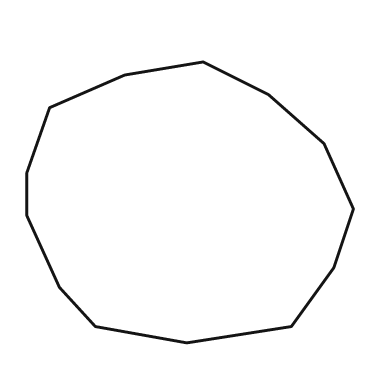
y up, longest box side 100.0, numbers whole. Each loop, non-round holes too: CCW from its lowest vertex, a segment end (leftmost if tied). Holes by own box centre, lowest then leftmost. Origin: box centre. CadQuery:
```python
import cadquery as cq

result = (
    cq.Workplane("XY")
    .moveTo(-1.0, -43.0)
    .lineTo(31.0, -38.0)
    .lineTo(44.0, -20.0)
    .lineTo(50.0, -2.0)
    .lineTo(41.0, 18.0)
    .lineTo(24.0, 33.0)
    .lineTo(4.0, 43.0)
    .lineTo(-20.0, 39.0)
    .lineTo(-43.0, 29.0)
    .lineTo(-50.0, 9.0)
    .lineTo(-50.0, -4.0)
    .lineTo(-40.0, -26.0)
    .lineTo(-29.0, -38.0)
    .close()
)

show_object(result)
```